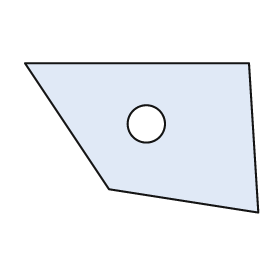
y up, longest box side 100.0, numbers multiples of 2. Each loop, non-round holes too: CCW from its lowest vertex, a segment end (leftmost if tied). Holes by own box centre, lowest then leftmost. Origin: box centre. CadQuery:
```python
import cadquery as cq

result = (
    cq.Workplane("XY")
    .moveTo(50.0, -32.0)
    .lineTo(46.0, 32.0)
    .lineTo(-50.0, 32.0)
    .lineTo(-14.0, -22.0)
    .close()
    .moveTo(2.0, 6.0)
    .circle(8.0)
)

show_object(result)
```